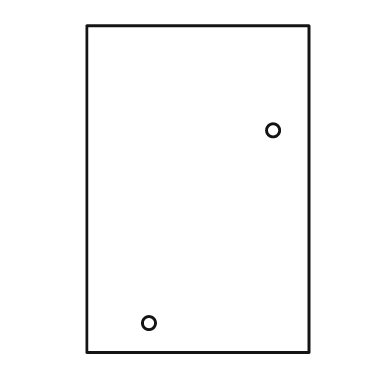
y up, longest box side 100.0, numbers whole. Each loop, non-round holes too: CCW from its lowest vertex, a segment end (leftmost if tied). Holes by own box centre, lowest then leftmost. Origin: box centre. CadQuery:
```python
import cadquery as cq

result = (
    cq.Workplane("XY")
    .moveTo(-34.0, -50.0)
    .lineTo(34.0, -50.0)
    .lineTo(34.0, 50.0)
    .lineTo(-34.0, 50.0)
    .close()
    .moveTo(-15.0, -41.0)
    .circle(2.0)
    .moveTo(23.0, 18.0)
    .circle(2.0)
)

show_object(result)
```